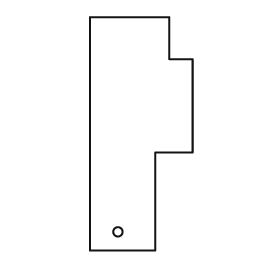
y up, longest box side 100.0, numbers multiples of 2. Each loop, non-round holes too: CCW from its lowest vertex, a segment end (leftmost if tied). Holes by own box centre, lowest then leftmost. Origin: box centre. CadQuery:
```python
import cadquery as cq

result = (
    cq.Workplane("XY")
    .moveTo(-22.0, -50.0)
    .lineTo(6.0, -50.0)
    .lineTo(6.0, -8.0)
    .lineTo(22.0, -8.0)
    .lineTo(22.0, 32.0)
    .lineTo(12.0, 32.0)
    .lineTo(12.0, 50.0)
    .lineTo(-22.0, 50.0)
    .close()
    .moveTo(-10.0, -42.0)
    .circle(2.0)
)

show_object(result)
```